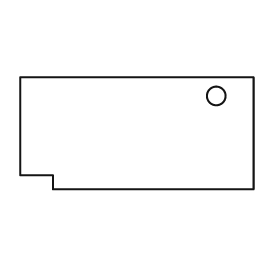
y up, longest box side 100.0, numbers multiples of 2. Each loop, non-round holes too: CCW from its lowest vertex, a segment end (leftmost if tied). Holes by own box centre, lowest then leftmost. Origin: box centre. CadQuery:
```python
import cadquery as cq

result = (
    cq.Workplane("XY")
    .moveTo(-36.0, -24.0)
    .lineTo(50.0, -24.0)
    .lineTo(50.0, 24.0)
    .lineTo(-50.0, 24.0)
    .lineTo(-50.0, -18.0)
    .lineTo(-36.0, -18.0)
    .close()
    .moveTo(34.0, 16.0)
    .circle(4.0)
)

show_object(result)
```